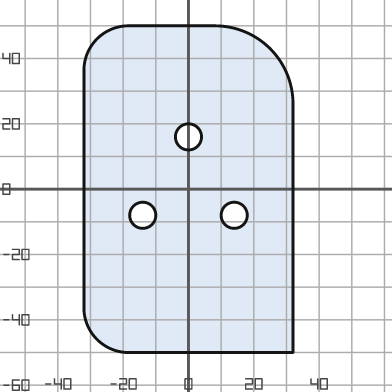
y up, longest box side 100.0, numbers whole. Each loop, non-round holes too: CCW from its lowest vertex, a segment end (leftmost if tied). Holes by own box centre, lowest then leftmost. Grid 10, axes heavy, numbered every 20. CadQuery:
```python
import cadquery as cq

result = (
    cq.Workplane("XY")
    .moveTo(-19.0, -50.0)
    .lineTo(32.0, -50.0)
    .lineTo(32.0, 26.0)
    .threePointArc((25.0, 43.0), (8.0, 50.0))
    .lineTo(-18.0, 50.0)
    .threePointArc((-28.0, 46.0), (-32.0, 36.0))
    .lineTo(-32.0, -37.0)
    .threePointArc((-28.0, -46.0), (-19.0, -50.0))
    .close()
    .moveTo(-14.0, -8.0)
    .circle(4.0)
    .moveTo(14.0, -8.0)
    .circle(4.0)
    .moveTo(0.0, 16.0)
    .circle(4.0)
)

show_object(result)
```